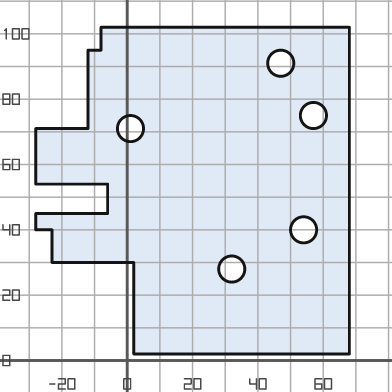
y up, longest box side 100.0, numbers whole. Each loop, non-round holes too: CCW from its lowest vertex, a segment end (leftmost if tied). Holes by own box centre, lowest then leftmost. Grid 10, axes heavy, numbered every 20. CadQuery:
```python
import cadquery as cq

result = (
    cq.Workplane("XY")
    .moveTo(2.0, 2.0)
    .lineTo(68.0, 2.0)
    .lineTo(68.0, 102.0)
    .lineTo(-8.0, 102.0)
    .lineTo(-8.0, 95.0)
    .lineTo(-12.0, 95.0)
    .lineTo(-12.0, 71.0)
    .lineTo(-28.0, 71.0)
    .lineTo(-28.0, 54.0)
    .lineTo(-6.0, 54.0)
    .lineTo(-6.0, 45.0)
    .lineTo(-28.0, 45.0)
    .lineTo(-28.0, 40.0)
    .lineTo(-23.0, 40.0)
    .lineTo(-23.0, 30.0)
    .lineTo(2.0, 30.0)
    .close()
    .moveTo(32.0, 28.0)
    .circle(4.0)
    .moveTo(54.0, 40.0)
    .circle(4.0)
    .moveTo(1.0, 71.0)
    .circle(4.0)
    .moveTo(57.0, 75.0)
    .circle(4.0)
    .moveTo(47.0, 91.0)
    .circle(4.0)
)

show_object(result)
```